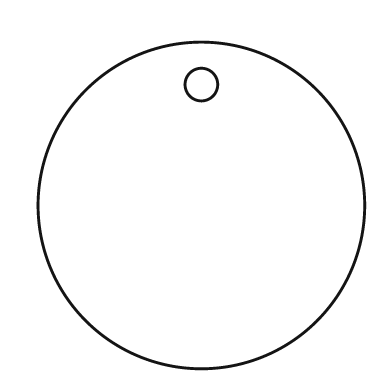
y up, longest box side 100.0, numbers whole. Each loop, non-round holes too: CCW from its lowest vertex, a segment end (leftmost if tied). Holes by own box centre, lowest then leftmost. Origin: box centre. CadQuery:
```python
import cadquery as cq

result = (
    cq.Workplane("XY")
    .moveTo(0.0, 0.0)
    .circle(50.0)
    .moveTo(0.0, 37.0)
    .circle(5.0)
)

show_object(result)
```